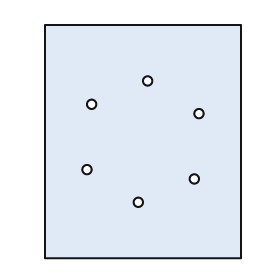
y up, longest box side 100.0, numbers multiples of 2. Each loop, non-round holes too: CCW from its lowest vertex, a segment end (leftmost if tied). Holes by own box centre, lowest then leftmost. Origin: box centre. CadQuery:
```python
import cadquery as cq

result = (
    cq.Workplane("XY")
    .moveTo(-42.0, -50.0)
    .lineTo(42.0, -50.0)
    .lineTo(42.0, 50.0)
    .lineTo(-42.0, 50.0)
    .close()
    .moveTo(-2.0, -26.0)
    .circle(2.0)
    .moveTo(22.0, -16.0)
    .circle(2.0)
    .moveTo(-24.0, -12.0)
    .circle(2.0)
    .moveTo(24.0, 12.0)
    .circle(2.0)
    .moveTo(-22.0, 16.0)
    .circle(2.0)
    .moveTo(2.0, 26.0)
    .circle(2.0)
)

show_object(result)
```